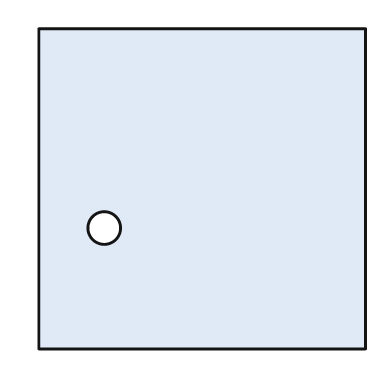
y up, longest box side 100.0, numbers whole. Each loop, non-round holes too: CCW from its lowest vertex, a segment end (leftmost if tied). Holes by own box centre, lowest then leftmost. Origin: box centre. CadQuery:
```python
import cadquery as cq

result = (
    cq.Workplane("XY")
    .moveTo(-50.0, -49.0)
    .lineTo(50.0, -49.0)
    .lineTo(50.0, 49.0)
    .lineTo(-50.0, 49.0)
    .close()
    .moveTo(-30.0, -12.0)
    .circle(5.0)
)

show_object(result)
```